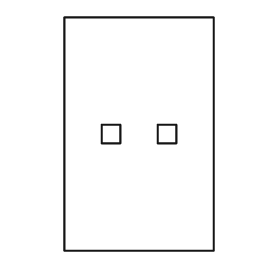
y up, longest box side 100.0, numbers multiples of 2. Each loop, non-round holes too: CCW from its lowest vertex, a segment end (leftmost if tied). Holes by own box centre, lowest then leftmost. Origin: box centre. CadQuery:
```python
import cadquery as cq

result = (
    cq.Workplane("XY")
    .moveTo(-32.0, -50.0)
    .lineTo(32.0, -50.0)
    .lineTo(32.0, 50.0)
    .lineTo(-32.0, 50.0)
    .close()
    .moveTo(-16.0, -4.0)
    .lineTo(-8.0, -4.0)
    .lineTo(-8.0, 4.0)
    .lineTo(-16.0, 4.0)
    .close()
    .moveTo(8.0, -4.0)
    .lineTo(16.0, -4.0)
    .lineTo(16.0, 4.0)
    .lineTo(8.0, 4.0)
    .close()
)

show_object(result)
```